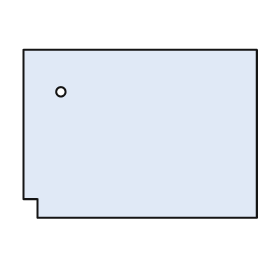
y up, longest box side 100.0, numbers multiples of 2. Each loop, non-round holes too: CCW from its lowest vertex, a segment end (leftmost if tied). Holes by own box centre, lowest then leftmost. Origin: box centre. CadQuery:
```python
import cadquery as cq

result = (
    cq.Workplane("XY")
    .moveTo(-44.0, -36.0)
    .lineTo(50.0, -36.0)
    .lineTo(50.0, 36.0)
    .lineTo(-50.0, 36.0)
    .lineTo(-50.0, -28.0)
    .lineTo(-44.0, -28.0)
    .close()
    .moveTo(-34.0, 18.0)
    .circle(2.0)
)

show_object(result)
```